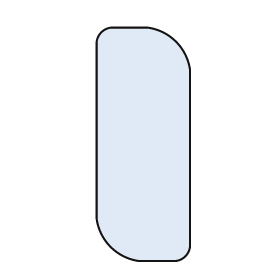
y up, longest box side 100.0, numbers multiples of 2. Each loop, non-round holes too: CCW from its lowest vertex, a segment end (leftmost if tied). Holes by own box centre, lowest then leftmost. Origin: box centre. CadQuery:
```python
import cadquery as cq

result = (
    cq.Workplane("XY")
    .moveTo(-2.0, -50.0)
    .lineTo(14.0, -50.0)
    .threePointArc((18.0, -48.0), (20.0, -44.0))
    .lineTo(20.0, 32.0)
    .threePointArc((14.0, 44.0), (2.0, 50.0))
    .lineTo(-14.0, 50.0)
    .threePointArc((-18.0, 48.0), (-20.0, 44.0))
    .lineTo(-20.0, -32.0)
    .threePointArc((-14.0, -44.0), (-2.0, -50.0))
    .close()
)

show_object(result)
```